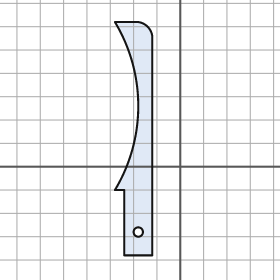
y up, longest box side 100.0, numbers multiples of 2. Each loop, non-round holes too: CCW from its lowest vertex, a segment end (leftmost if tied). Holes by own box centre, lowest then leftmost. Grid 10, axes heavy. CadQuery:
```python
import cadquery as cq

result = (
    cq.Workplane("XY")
    .moveTo(-24.0, -38.0)
    .lineTo(-12.0, -38.0)
    .lineTo(-12.0, 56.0)
    .threePointArc((-14.0, 60.0), (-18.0, 62.0))
    .lineTo(-28.0, 62.0)
    .threePointArc((-18.0, 26.0), (-28.0, -10.0))
    .lineTo(-24.0, -10.0)
    .close()
    .moveTo(-18.0, -28.0)
    .circle(2.0)
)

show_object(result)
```